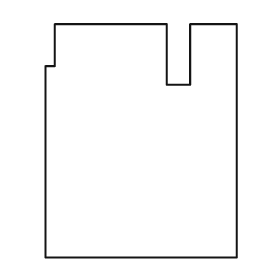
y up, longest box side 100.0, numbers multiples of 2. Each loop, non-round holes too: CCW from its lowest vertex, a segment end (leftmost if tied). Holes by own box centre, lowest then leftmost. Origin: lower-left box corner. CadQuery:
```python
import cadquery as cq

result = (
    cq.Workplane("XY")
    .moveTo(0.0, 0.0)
    .lineTo(82.0, 0.0)
    .lineTo(82.0, 100.0)
    .lineTo(62.0, 100.0)
    .lineTo(62.0, 74.0)
    .lineTo(52.0, 74.0)
    .lineTo(52.0, 100.0)
    .lineTo(4.0, 100.0)
    .lineTo(4.0, 82.0)
    .lineTo(0.0, 82.0)
    .close()
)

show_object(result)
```